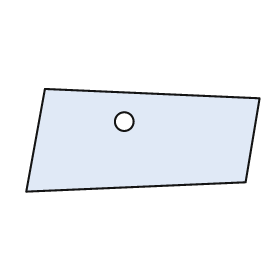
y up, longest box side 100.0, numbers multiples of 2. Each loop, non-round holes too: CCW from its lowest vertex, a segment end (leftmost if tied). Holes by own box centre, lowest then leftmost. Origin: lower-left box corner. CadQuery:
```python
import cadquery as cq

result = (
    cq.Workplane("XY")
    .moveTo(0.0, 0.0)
    .lineTo(94.0, 4.0)
    .lineTo(100.0, 40.0)
    .lineTo(8.0, 44.0)
    .close()
    .moveTo(42.0, 30.0)
    .circle(4.0)
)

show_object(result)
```